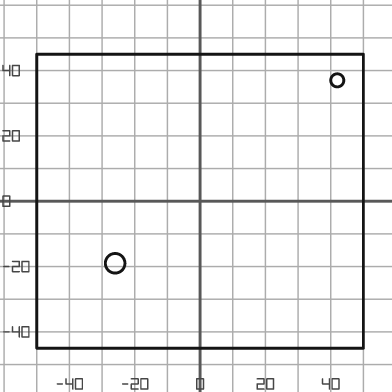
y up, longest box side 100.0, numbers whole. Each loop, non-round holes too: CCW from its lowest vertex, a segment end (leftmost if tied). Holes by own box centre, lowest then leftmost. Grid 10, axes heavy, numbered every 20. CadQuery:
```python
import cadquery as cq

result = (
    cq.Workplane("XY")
    .moveTo(-50.0, -45.0)
    .lineTo(50.0, -45.0)
    .lineTo(50.0, 45.0)
    .lineTo(-50.0, 45.0)
    .close()
    .moveTo(-26.0, -19.0)
    .circle(3.0)
    .moveTo(42.0, 37.0)
    .circle(2.0)
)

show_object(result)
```